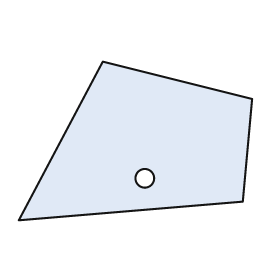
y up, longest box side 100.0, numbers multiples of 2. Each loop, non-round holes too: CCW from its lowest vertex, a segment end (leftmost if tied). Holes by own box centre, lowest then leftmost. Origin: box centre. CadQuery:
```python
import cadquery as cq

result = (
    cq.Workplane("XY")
    .moveTo(-50.0, -34.0)
    .lineTo(46.0, -26.0)
    .lineTo(50.0, 18.0)
    .lineTo(-14.0, 34.0)
    .close()
    .moveTo(4.0, -16.0)
    .circle(4.0)
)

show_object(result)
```